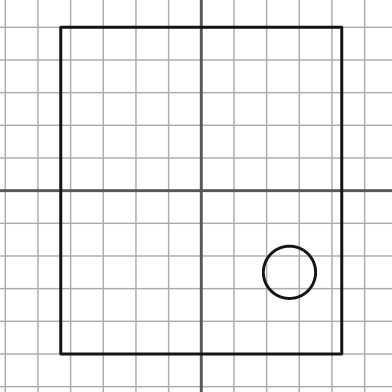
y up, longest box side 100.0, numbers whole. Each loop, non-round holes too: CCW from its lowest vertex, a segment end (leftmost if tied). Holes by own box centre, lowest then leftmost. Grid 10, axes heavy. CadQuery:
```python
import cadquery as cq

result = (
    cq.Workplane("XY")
    .moveTo(-43.0, -50.0)
    .lineTo(43.0, -50.0)
    .lineTo(43.0, 50.0)
    .lineTo(-43.0, 50.0)
    .close()
    .moveTo(27.0, -25.0)
    .circle(8.0)
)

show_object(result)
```